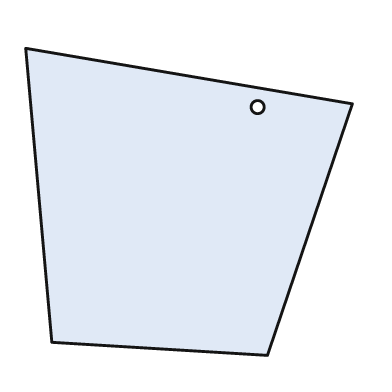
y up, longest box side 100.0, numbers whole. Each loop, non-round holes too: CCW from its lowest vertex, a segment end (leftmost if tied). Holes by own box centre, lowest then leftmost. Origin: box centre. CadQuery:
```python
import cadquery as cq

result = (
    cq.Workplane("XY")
    .moveTo(24.0, -47.0)
    .lineTo(50.0, 30.0)
    .lineTo(-50.0, 47.0)
    .lineTo(-42.0, -43.0)
    .close()
    .moveTo(21.0, 29.0)
    .circle(2.0)
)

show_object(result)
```